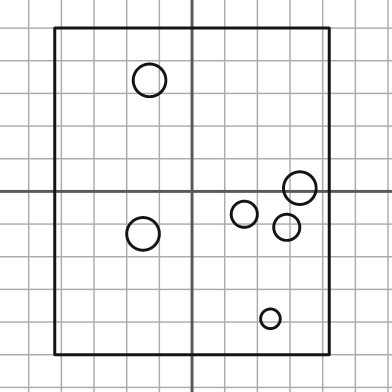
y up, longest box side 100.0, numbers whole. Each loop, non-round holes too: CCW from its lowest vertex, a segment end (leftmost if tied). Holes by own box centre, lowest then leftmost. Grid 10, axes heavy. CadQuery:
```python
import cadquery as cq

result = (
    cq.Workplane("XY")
    .moveTo(-42.0, -50.0)
    .lineTo(42.0, -50.0)
    .lineTo(42.0, 50.0)
    .lineTo(-42.0, 50.0)
    .close()
    .moveTo(24.0, -39.0)
    .circle(3.0)
    .moveTo(-15.0, -13.0)
    .circle(5.0)
    .moveTo(29.0, -11.0)
    .circle(4.0)
    .moveTo(16.0, -7.0)
    .circle(4.0)
    .moveTo(33.0, 1.0)
    .circle(5.0)
    .moveTo(-13.0, 34.0)
    .circle(5.0)
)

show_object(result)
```